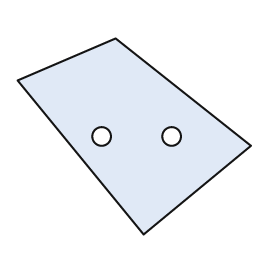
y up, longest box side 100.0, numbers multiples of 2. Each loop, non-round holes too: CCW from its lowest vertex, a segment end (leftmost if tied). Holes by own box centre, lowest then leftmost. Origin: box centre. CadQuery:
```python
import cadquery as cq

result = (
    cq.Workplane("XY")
    .moveTo(4.0, -42.0)
    .lineTo(50.0, -4.0)
    .lineTo(-8.0, 42.0)
    .lineTo(-50.0, 24.0)
    .close()
    .moveTo(-14.0, 0.0)
    .circle(4.0)
    .moveTo(16.0, 0.0)
    .circle(4.0)
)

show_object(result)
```